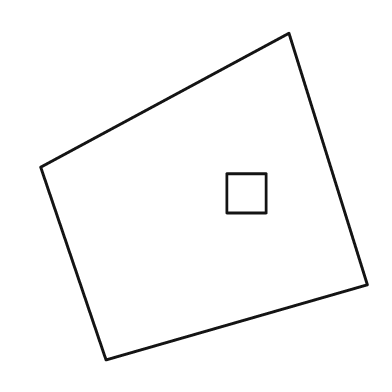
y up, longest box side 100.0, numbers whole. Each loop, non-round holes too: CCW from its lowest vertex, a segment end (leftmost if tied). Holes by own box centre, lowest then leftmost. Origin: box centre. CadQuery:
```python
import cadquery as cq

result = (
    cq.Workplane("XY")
    .moveTo(-30.0, -50.0)
    .lineTo(50.0, -27.0)
    .lineTo(26.0, 50.0)
    .lineTo(-50.0, 9.0)
    .close()
    .moveTo(7.0, -5.0)
    .lineTo(19.0, -5.0)
    .lineTo(19.0, 7.0)
    .lineTo(7.0, 7.0)
    .close()
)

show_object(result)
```